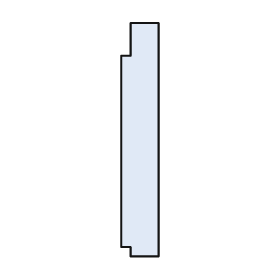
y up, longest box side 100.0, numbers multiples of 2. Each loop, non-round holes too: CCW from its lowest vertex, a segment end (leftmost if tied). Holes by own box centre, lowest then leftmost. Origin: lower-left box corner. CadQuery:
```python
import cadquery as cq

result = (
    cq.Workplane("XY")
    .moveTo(4.0, 0.0)
    .lineTo(16.0, 0.0)
    .lineTo(16.0, 100.0)
    .lineTo(4.0, 100.0)
    .lineTo(4.0, 86.0)
    .lineTo(0.0, 86.0)
    .lineTo(0.0, 4.0)
    .lineTo(4.0, 4.0)
    .close()
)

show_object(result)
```